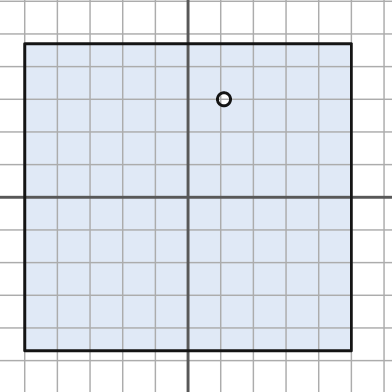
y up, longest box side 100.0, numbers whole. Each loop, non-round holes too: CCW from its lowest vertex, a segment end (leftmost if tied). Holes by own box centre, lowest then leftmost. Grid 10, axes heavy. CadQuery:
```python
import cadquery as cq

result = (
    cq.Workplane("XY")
    .moveTo(-50.0, -47.0)
    .lineTo(50.0, -47.0)
    .lineTo(50.0, 47.0)
    .lineTo(-50.0, 47.0)
    .close()
    .moveTo(11.0, 30.0)
    .circle(2.0)
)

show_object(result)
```